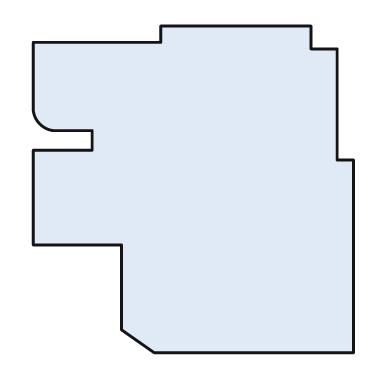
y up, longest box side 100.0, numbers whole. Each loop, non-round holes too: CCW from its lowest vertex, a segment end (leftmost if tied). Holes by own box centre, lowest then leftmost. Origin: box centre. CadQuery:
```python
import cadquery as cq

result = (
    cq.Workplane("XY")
    .moveTo(-12.0, -50.0)
    .lineTo(49.0, -50.0)
    .lineTo(49.0, 9.0)
    .lineTo(44.0, 9.0)
    .lineTo(44.0, 43.0)
    .lineTo(36.0, 43.0)
    .lineTo(36.0, 50.0)
    .lineTo(-10.0, 50.0)
    .lineTo(-10.0, 45.0)
    .lineTo(-49.0, 45.0)
    .lineTo(-49.0, 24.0)
    .threePointArc((-47.0, 20.0), (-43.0, 18.0))
    .lineTo(-31.0, 18.0)
    .lineTo(-31.0, 12.0)
    .lineTo(-49.0, 12.0)
    .lineTo(-49.0, -17.0)
    .lineTo(-22.0, -17.0)
    .lineTo(-22.0, -43.0)
    .close()
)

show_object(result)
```